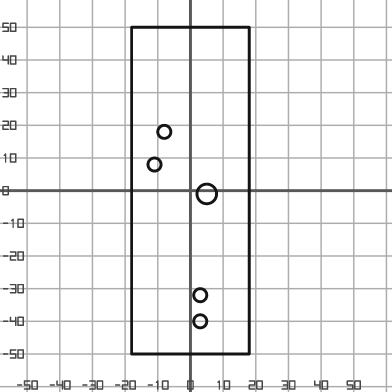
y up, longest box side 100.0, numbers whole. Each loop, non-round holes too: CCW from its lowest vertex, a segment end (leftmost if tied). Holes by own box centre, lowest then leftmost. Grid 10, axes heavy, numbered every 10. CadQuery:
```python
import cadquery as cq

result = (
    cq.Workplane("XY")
    .moveTo(-18.0, -50.0)
    .lineTo(18.0, -50.0)
    .lineTo(18.0, 50.0)
    .lineTo(-18.0, 50.0)
    .close()
    .moveTo(3.0, -40.0)
    .circle(2.0)
    .moveTo(3.0, -32.0)
    .circle(2.0)
    .moveTo(5.0, -1.0)
    .circle(3.0)
    .moveTo(-11.0, 8.0)
    .circle(2.0)
    .moveTo(-8.0, 18.0)
    .circle(2.0)
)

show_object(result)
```